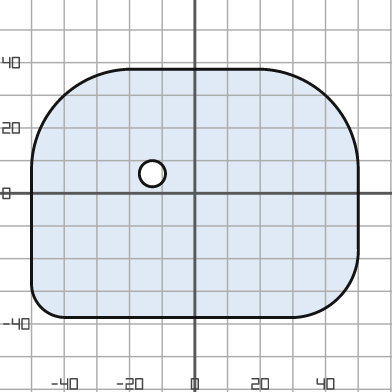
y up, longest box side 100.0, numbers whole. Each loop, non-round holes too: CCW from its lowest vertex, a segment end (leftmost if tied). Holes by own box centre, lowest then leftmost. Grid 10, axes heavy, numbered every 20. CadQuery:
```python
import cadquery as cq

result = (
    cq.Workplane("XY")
    .moveTo(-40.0, -38.0)
    .lineTo(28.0, -38.0)
    .threePointArc((44.0, -32.0), (50.0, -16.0))
    .lineTo(50.0, 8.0)
    .threePointArc((41.0, 29.0), (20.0, 38.0))
    .lineTo(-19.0, 38.0)
    .threePointArc((-41.0, 29.0), (-50.0, 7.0))
    .lineTo(-50.0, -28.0)
    .threePointArc((-47.0, -35.0), (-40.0, -38.0))
    .close()
    .moveTo(-13.0, 6.0)
    .circle(4.0)
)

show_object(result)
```